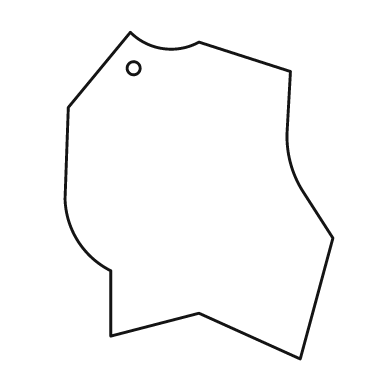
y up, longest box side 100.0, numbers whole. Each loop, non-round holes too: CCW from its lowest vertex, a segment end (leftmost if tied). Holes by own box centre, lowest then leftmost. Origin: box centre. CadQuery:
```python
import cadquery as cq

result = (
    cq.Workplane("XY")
    .moveTo(31.0, -50.0)
    .lineTo(41.0, -13.0)
    .lineTo(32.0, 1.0)
    .threePointArc((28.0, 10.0), (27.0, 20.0))
    .lineTo(28.0, 38.0)
    .lineTo(0.0, 47.0)
    .threePointArc((-11.0, 45.0), (-21.0, 50.0))
    .lineTo(-40.0, 27.0)
    .lineTo(-41.0, -1.0)
    .threePointArc((-37.0, -14.0), (-27.0, -23.0))
    .lineTo(-27.0, -43.0)
    .lineTo(0.0, -36.0)
    .close()
    .moveTo(-20.0, 39.0)
    .circle(2.0)
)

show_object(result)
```